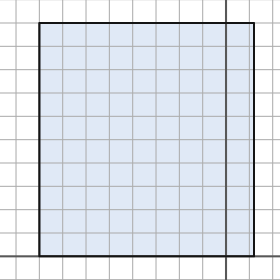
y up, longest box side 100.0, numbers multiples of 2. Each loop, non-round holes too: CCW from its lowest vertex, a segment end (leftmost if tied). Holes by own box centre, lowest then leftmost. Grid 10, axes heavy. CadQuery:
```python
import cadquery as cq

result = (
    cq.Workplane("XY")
    .moveTo(-80.0, 0.0)
    .lineTo(12.0, 0.0)
    .lineTo(12.0, 100.0)
    .lineTo(-80.0, 100.0)
    .close()
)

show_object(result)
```